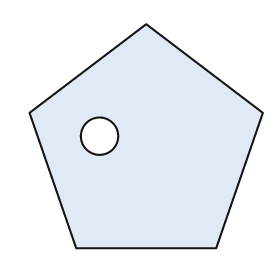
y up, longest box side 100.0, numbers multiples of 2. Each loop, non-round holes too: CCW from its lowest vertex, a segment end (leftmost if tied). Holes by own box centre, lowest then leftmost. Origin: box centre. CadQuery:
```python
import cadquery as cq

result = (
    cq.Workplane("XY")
    .moveTo(-30.0, -48.0)
    .lineTo(30.0, -48.0)
    .lineTo(50.0, 10.0)
    .lineTo(0.0, 48.0)
    .lineTo(-50.0, 10.0)
    .close()
    .moveTo(-20.0, 0.0)
    .circle(8.0)
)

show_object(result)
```